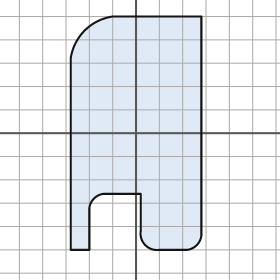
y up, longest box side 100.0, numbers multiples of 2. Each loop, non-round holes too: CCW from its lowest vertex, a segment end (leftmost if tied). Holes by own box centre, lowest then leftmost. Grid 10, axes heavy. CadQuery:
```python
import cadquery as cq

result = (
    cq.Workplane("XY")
    .moveTo(-28.0, -50.0)
    .lineTo(-20.0, -50.0)
    .lineTo(-20.0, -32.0)
    .threePointArc((-18.0, -28.0), (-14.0, -26.0))
    .lineTo(2.0, -26.0)
    .lineTo(2.0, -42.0)
    .threePointArc((4.0, -48.0), (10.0, -50.0))
    .lineTo(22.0, -50.0)
    .threePointArc((26.0, -48.0), (28.0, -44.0))
    .lineTo(28.0, 50.0)
    .lineTo(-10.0, 50.0)
    .threePointArc((-22.0, 44.0), (-28.0, 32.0))
    .close()
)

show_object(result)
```